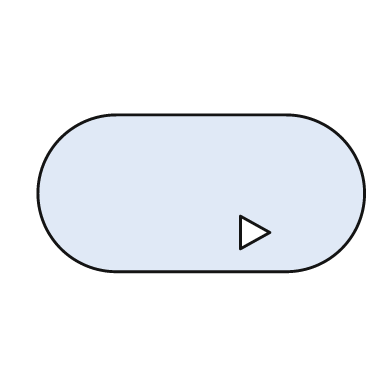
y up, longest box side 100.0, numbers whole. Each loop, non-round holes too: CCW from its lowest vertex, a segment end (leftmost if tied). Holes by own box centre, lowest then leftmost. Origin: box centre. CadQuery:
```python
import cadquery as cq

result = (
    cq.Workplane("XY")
    .moveTo(-26.0, -24.0)
    .lineTo(26.0, -24.0)
    .threePointArc((50.0, 0.0), (26.0, 24.0))
    .lineTo(-26.0, 24.0)
    .threePointArc((-50.0, 0.0), (-26.0, -24.0))
    .close()
    .moveTo(12.0, -17.0)
    .lineTo(21.0, -12.0)
    .lineTo(12.0, -7.0)
    .close()
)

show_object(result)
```